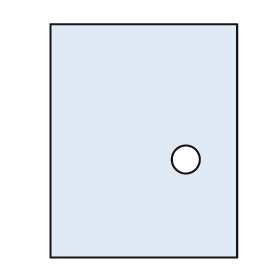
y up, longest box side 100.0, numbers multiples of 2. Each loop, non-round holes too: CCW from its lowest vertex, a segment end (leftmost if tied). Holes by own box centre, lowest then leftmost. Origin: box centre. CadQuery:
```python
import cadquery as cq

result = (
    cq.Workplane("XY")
    .moveTo(-40.0, -50.0)
    .lineTo(40.0, -50.0)
    .lineTo(40.0, 50.0)
    .lineTo(-40.0, 50.0)
    .close()
    .moveTo(18.0, -8.0)
    .circle(6.0)
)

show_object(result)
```